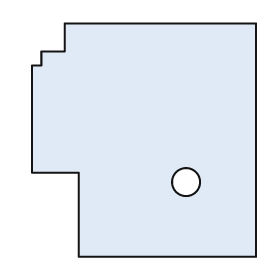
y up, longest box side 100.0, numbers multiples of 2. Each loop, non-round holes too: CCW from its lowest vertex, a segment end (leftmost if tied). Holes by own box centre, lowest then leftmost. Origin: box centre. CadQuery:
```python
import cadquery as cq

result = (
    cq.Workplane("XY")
    .moveTo(-28.0, -50.0)
    .lineTo(48.0, -50.0)
    .lineTo(48.0, 50.0)
    .lineTo(-34.0, 50.0)
    .lineTo(-34.0, 38.0)
    .lineTo(-44.0, 38.0)
    .lineTo(-44.0, 32.0)
    .lineTo(-48.0, 32.0)
    .lineTo(-48.0, -14.0)
    .lineTo(-28.0, -14.0)
    .close()
    .moveTo(18.0, -18.0)
    .circle(6.0)
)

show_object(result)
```